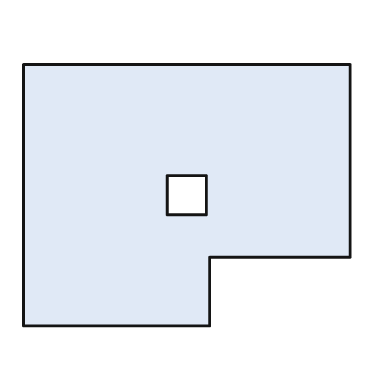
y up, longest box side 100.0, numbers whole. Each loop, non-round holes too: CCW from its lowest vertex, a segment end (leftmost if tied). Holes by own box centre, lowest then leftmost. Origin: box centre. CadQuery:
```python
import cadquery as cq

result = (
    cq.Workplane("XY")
    .moveTo(-50.0, -40.0)
    .lineTo(7.0, -40.0)
    .lineTo(7.0, -19.0)
    .lineTo(50.0, -19.0)
    .lineTo(50.0, 40.0)
    .lineTo(-50.0, 40.0)
    .close()
    .moveTo(-6.0, -6.0)
    .lineTo(6.0, -6.0)
    .lineTo(6.0, 6.0)
    .lineTo(-6.0, 6.0)
    .close()
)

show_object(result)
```